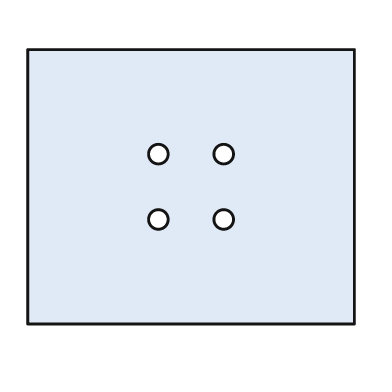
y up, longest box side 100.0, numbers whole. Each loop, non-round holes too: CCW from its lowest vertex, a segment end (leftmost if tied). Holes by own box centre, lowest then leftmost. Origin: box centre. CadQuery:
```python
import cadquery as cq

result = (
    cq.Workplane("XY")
    .moveTo(-50.0, -42.0)
    .lineTo(50.0, -42.0)
    .lineTo(50.0, 42.0)
    .lineTo(-50.0, 42.0)
    .close()
    .moveTo(-10.0, -10.0)
    .circle(3.0)
    .moveTo(10.0, -10.0)
    .circle(3.0)
    .moveTo(-10.0, 10.0)
    .circle(3.0)
    .moveTo(10.0, 10.0)
    .circle(3.0)
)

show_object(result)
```